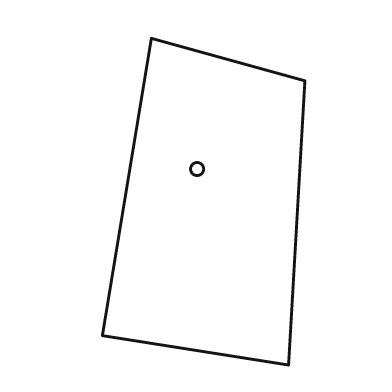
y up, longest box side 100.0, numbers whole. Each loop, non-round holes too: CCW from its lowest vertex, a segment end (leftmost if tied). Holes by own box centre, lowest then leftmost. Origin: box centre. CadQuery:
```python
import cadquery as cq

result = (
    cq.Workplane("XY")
    .moveTo(26.0, -50.0)
    .lineTo(31.0, 37.0)
    .lineTo(-16.0, 50.0)
    .lineTo(-31.0, -41.0)
    .close()
    .moveTo(-2.0, 10.0)
    .circle(2.0)
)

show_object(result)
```